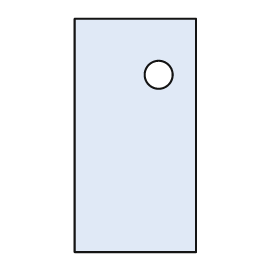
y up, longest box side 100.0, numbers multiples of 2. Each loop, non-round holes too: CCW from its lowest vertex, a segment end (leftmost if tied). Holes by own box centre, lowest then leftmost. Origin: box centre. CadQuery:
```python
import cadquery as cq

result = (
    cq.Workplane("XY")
    .moveTo(-26.0, -50.0)
    .lineTo(26.0, -50.0)
    .lineTo(26.0, 50.0)
    .lineTo(-26.0, 50.0)
    .close()
    .moveTo(10.0, 26.0)
    .circle(6.0)
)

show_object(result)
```